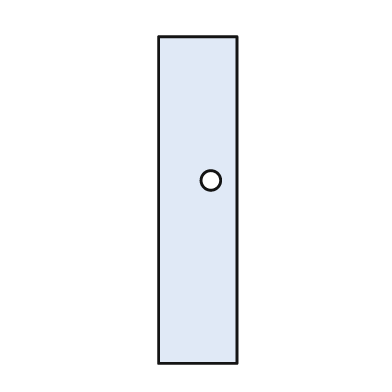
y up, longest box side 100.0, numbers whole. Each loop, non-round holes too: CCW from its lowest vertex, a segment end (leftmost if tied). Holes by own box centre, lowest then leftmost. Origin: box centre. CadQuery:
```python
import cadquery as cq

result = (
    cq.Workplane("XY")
    .moveTo(-12.0, -50.0)
    .lineTo(12.0, -50.0)
    .lineTo(12.0, 50.0)
    .lineTo(-12.0, 50.0)
    .close()
    .moveTo(4.0, 6.0)
    .circle(3.0)
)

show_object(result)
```